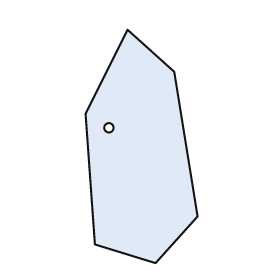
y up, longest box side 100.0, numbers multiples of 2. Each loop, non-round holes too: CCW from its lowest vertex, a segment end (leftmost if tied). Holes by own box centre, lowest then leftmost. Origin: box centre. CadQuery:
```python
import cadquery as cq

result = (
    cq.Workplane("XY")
    .moveTo(6.0, -50.0)
    .lineTo(24.0, -30.0)
    .lineTo(14.0, 32.0)
    .lineTo(-6.0, 50.0)
    .lineTo(-24.0, 14.0)
    .lineTo(-20.0, -42.0)
    .close()
    .moveTo(-14.0, 8.0)
    .circle(2.0)
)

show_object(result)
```